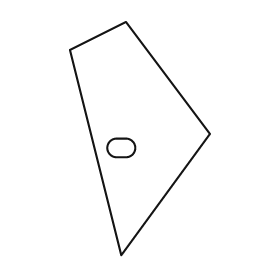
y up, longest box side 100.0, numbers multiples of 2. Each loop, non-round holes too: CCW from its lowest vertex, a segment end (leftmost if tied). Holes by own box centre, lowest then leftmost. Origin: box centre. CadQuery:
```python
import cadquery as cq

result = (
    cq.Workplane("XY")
    .moveTo(-8.0, -50.0)
    .lineTo(30.0, 2.0)
    .lineTo(-6.0, 50.0)
    .lineTo(-30.0, 38.0)
    .close()
    .moveTo(-10.0, -8.0)
    .lineTo(-6.0, -8.0)
    .threePointArc((-2.0, -4.0), (-6.0, 0.0))
    .lineTo(-10.0, 0.0)
    .threePointArc((-14.0, -4.0), (-10.0, -8.0))
    .close()
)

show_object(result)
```